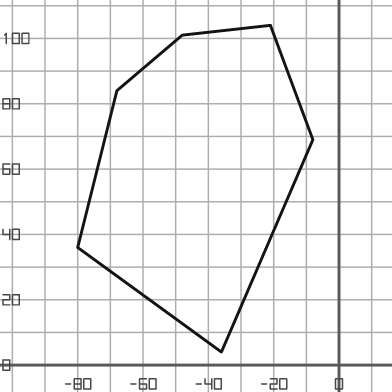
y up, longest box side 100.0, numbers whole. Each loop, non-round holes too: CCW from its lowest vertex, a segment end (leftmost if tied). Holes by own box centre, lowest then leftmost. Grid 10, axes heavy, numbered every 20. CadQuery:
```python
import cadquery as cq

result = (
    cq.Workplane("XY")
    .moveTo(-36.0, 4.0)
    .lineTo(-8.0, 69.0)
    .lineTo(-21.0, 104.0)
    .lineTo(-48.0, 101.0)
    .lineTo(-68.0, 84.0)
    .lineTo(-80.0, 36.0)
    .close()
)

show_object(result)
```